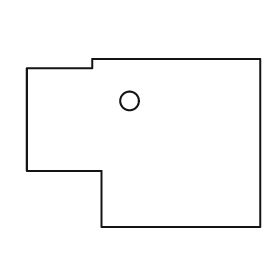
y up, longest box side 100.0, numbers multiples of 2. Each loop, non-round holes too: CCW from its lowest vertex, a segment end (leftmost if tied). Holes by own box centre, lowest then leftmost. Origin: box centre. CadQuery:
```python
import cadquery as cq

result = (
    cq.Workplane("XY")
    .moveTo(-18.0, -36.0)
    .lineTo(50.0, -36.0)
    .lineTo(50.0, 36.0)
    .lineTo(-22.0, 36.0)
    .lineTo(-22.0, 32.0)
    .lineTo(-50.0, 32.0)
    .lineTo(-50.0, -12.0)
    .lineTo(-18.0, -12.0)
    .close()
    .moveTo(-6.0, 18.0)
    .circle(4.0)
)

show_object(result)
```